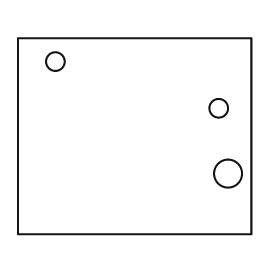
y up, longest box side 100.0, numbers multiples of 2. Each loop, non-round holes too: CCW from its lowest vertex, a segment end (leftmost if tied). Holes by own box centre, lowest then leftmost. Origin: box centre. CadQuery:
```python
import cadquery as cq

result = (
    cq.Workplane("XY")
    .moveTo(-50.0, -42.0)
    .lineTo(50.0, -42.0)
    .lineTo(50.0, 42.0)
    .lineTo(-50.0, 42.0)
    .close()
    .moveTo(40.0, -16.0)
    .circle(6.0)
    .moveTo(36.0, 12.0)
    .circle(4.0)
    .moveTo(-34.0, 32.0)
    .circle(4.0)
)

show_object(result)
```